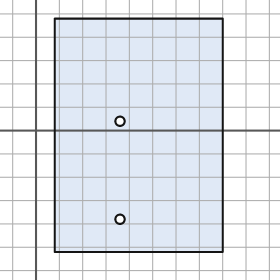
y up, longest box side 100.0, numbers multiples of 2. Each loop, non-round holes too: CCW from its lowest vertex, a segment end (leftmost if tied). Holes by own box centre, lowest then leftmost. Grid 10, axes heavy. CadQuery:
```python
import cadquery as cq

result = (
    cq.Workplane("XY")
    .moveTo(8.0, -52.0)
    .lineTo(80.0, -52.0)
    .lineTo(80.0, 48.0)
    .lineTo(8.0, 48.0)
    .close()
    .moveTo(36.0, -38.0)
    .circle(2.0)
    .moveTo(36.0, 4.0)
    .circle(2.0)
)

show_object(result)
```